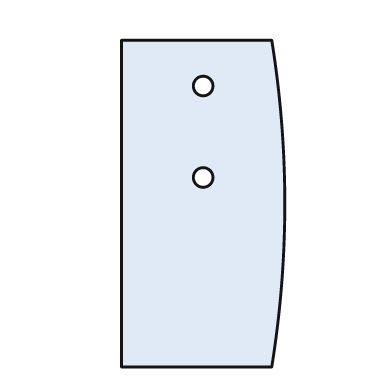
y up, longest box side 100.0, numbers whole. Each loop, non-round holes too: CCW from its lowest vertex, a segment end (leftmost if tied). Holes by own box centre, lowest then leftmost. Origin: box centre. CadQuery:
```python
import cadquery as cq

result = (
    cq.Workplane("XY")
    .moveTo(-25.0, -50.0)
    .lineTo(21.0, -50.0)
    .threePointArc((25.0, 0.0), (21.0, 50.0))
    .lineTo(-25.0, 50.0)
    .close()
    .moveTo(0.0, 8.0)
    .circle(3.0)
    .moveTo(0.0, 36.0)
    .circle(3.0)
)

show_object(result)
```